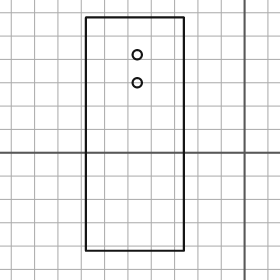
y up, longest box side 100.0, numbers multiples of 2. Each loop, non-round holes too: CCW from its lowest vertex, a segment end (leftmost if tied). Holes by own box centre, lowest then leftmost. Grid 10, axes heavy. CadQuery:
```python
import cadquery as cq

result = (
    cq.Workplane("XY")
    .moveTo(-68.0, -42.0)
    .lineTo(-26.0, -42.0)
    .lineTo(-26.0, 58.0)
    .lineTo(-68.0, 58.0)
    .close()
    .moveTo(-46.0, 30.0)
    .circle(2.0)
    .moveTo(-46.0, 42.0)
    .circle(2.0)
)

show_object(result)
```